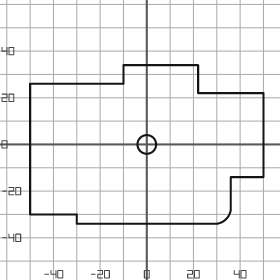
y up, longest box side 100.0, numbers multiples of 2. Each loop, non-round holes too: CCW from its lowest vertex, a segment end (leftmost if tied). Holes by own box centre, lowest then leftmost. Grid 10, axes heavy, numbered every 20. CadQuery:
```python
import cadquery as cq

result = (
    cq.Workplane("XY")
    .moveTo(-30.0, -34.0)
    .lineTo(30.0, -34.0)
    .threePointArc((34.0, -32.0), (36.0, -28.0))
    .lineTo(36.0, -14.0)
    .lineTo(50.0, -14.0)
    .lineTo(50.0, 22.0)
    .lineTo(22.0, 22.0)
    .lineTo(22.0, 34.0)
    .lineTo(-10.0, 34.0)
    .lineTo(-10.0, 26.0)
    .lineTo(-50.0, 26.0)
    .lineTo(-50.0, -30.0)
    .lineTo(-30.0, -30.0)
    .close()
    .moveTo(0.0, 0.0)
    .circle(4.0)
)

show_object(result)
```